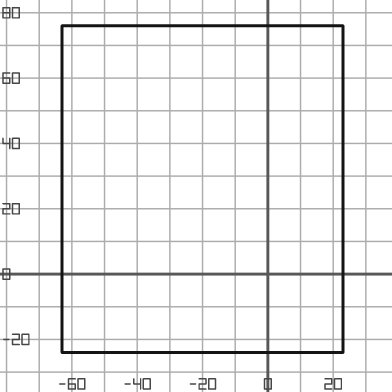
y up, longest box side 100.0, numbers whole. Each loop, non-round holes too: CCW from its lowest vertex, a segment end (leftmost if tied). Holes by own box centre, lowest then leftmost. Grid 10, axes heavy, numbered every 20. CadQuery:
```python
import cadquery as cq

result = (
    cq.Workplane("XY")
    .moveTo(-63.0, -24.0)
    .lineTo(23.0, -24.0)
    .lineTo(23.0, 76.0)
    .lineTo(-63.0, 76.0)
    .close()
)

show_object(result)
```